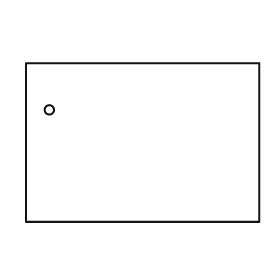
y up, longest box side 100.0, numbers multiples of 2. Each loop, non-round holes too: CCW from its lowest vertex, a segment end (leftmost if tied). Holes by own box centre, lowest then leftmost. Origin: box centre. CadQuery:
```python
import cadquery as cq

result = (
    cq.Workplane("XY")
    .moveTo(-50.0, -34.0)
    .lineTo(50.0, -34.0)
    .lineTo(50.0, 34.0)
    .lineTo(-50.0, 34.0)
    .close()
    .moveTo(-40.0, 14.0)
    .circle(2.0)
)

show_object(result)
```